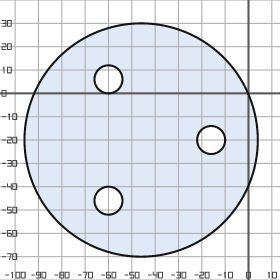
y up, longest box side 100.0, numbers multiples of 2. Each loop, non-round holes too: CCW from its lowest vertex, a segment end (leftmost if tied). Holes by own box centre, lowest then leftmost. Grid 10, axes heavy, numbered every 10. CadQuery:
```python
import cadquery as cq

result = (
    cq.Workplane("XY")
    .moveTo(-46.0, -20.0)
    .circle(50.0)
    .moveTo(-60.0, -46.0)
    .circle(6.0)
    .moveTo(-16.0, -20.0)
    .circle(6.0)
    .moveTo(-60.0, 6.0)
    .circle(6.0)
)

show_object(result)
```